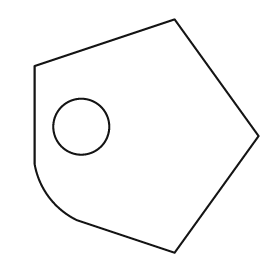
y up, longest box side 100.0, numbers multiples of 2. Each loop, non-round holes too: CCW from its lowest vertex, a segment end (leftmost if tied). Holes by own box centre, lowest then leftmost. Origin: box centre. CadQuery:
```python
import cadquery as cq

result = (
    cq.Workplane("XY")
    .moveTo(12.0, -50.0)
    .lineTo(48.0, 0.0)
    .lineTo(12.0, 50.0)
    .lineTo(-48.0, 30.0)
    .lineTo(-48.0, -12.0)
    .threePointArc((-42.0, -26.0), (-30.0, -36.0))
    .close()
    .moveTo(-28.0, 4.0)
    .circle(12.0)
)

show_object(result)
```